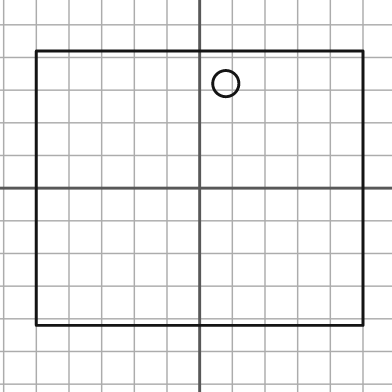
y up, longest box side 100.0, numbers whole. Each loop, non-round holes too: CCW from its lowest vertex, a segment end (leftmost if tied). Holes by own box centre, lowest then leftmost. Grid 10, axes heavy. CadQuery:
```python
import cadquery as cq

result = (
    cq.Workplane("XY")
    .moveTo(-50.0, -42.0)
    .lineTo(50.0, -42.0)
    .lineTo(50.0, 42.0)
    .lineTo(-50.0, 42.0)
    .close()
    .moveTo(8.0, 32.0)
    .circle(4.0)
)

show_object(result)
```